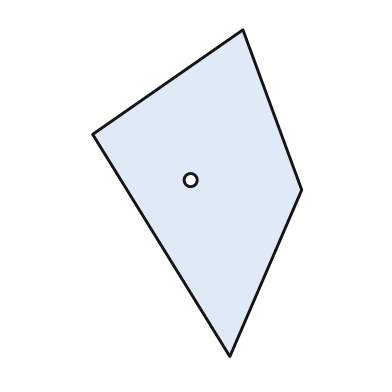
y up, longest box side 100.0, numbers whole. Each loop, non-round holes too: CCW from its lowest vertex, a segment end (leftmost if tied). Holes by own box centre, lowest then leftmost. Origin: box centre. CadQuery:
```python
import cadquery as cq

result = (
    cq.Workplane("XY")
    .moveTo(10.0, -50.0)
    .lineTo(32.0, 1.0)
    .lineTo(14.0, 50.0)
    .lineTo(-32.0, 18.0)
    .close()
    .moveTo(-2.0, 4.0)
    .circle(2.0)
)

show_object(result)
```